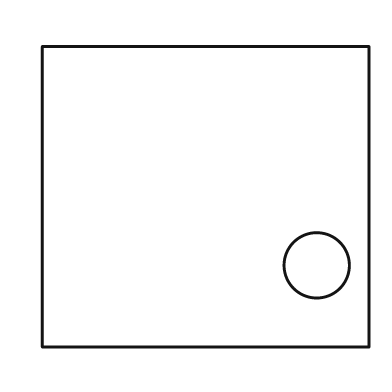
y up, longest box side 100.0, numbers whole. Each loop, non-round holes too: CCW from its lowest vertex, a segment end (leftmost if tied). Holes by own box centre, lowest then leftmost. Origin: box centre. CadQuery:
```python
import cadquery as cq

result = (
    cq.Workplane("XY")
    .moveTo(-50.0, -46.0)
    .lineTo(50.0, -46.0)
    .lineTo(50.0, 46.0)
    .lineTo(-50.0, 46.0)
    .close()
    .moveTo(34.0, -21.0)
    .circle(10.0)
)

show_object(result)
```